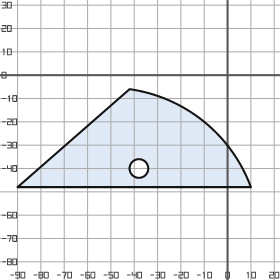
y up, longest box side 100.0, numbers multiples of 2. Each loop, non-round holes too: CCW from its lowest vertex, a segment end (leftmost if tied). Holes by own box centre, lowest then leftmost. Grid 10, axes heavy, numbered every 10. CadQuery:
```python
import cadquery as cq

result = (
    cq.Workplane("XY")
    .moveTo(-90.0, -48.0)
    .lineTo(10.0, -48.0)
    .threePointArc((-10.0, -20.0), (-42.0, -6.0))
    .close()
    .moveTo(-38.0, -40.0)
    .circle(4.0)
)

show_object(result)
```